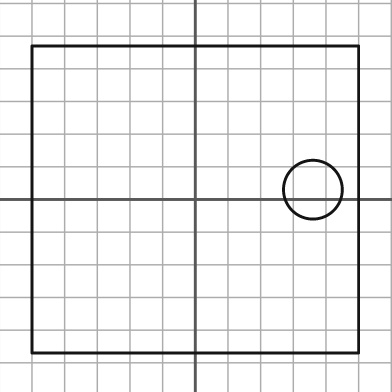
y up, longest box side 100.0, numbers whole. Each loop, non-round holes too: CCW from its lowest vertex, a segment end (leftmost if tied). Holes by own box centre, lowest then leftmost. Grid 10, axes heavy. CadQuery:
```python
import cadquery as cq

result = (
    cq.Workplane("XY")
    .moveTo(-50.0, -47.0)
    .lineTo(50.0, -47.0)
    .lineTo(50.0, 47.0)
    .lineTo(-50.0, 47.0)
    .close()
    .moveTo(36.0, 3.0)
    .circle(9.0)
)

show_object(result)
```